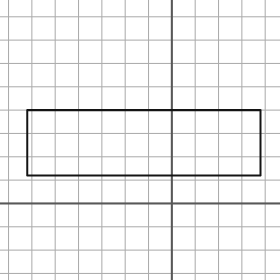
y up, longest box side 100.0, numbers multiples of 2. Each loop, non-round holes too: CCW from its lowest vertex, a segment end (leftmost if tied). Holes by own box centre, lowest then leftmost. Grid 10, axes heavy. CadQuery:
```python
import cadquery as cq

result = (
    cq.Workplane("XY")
    .moveTo(-62.0, 12.0)
    .lineTo(38.0, 12.0)
    .lineTo(38.0, 40.0)
    .lineTo(-62.0, 40.0)
    .close()
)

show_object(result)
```